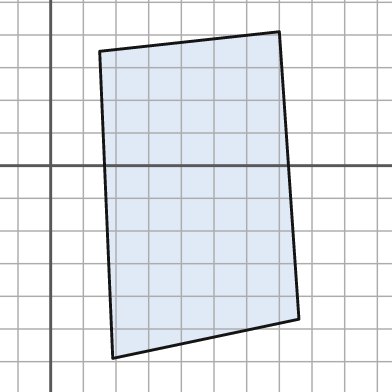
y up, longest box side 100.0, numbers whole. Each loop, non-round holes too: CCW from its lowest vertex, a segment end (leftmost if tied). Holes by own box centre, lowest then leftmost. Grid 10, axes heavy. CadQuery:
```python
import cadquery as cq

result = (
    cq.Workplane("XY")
    .moveTo(19.0, -59.0)
    .lineTo(76.0, -47.0)
    .lineTo(70.0, 41.0)
    .lineTo(15.0, 35.0)
    .close()
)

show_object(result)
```